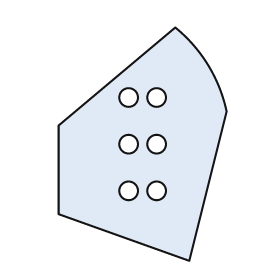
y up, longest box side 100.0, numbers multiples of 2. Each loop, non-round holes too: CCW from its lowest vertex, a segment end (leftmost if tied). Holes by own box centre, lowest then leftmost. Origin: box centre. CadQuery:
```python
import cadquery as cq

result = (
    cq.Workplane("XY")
    .moveTo(20.0, -50.0)
    .lineTo(36.0, 14.0)
    .threePointArc((28.0, 34.0), (14.0, 50.0))
    .lineTo(-36.0, 8.0)
    .lineTo(-36.0, -30.0)
    .close()
    .moveTo(-6.0, -20.0)
    .circle(4.0)
    .moveTo(6.0, -20.0)
    .circle(4.0)
    .moveTo(-6.0, 0.0)
    .circle(4.0)
    .moveTo(6.0, 0.0)
    .circle(4.0)
    .moveTo(-6.0, 20.0)
    .circle(4.0)
    .moveTo(6.0, 20.0)
    .circle(4.0)
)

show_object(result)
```